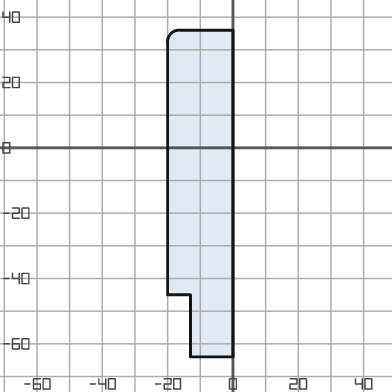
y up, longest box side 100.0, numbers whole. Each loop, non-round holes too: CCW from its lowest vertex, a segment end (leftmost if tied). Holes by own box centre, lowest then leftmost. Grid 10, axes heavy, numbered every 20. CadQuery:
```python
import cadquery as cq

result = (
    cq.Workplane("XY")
    .moveTo(-13.0, -64.0)
    .lineTo(0.0, -64.0)
    .lineTo(0.0, 36.0)
    .lineTo(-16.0, 36.0)
    .threePointArc((-19.0, 35.0), (-20.0, 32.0))
    .lineTo(-20.0, -45.0)
    .lineTo(-13.0, -45.0)
    .close()
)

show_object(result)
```